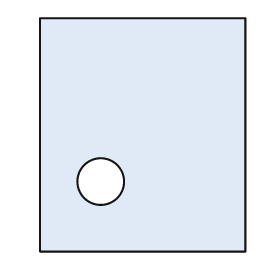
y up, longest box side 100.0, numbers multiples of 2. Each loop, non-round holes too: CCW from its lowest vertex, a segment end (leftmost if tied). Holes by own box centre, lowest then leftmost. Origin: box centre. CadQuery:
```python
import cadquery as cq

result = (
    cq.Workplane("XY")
    .moveTo(-44.0, -50.0)
    .lineTo(44.0, -50.0)
    .lineTo(44.0, 50.0)
    .lineTo(-44.0, 50.0)
    .close()
    .moveTo(-18.0, -20.0)
    .circle(10.0)
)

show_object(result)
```